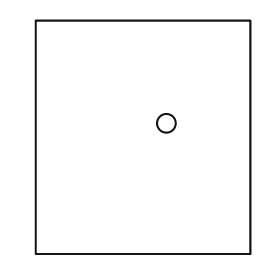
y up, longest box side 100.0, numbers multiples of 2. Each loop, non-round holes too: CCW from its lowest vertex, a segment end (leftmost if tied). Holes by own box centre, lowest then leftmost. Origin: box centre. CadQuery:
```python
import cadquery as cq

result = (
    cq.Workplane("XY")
    .moveTo(-46.0, -50.0)
    .lineTo(46.0, -50.0)
    .lineTo(46.0, 50.0)
    .lineTo(-46.0, 50.0)
    .close()
    .moveTo(10.0, 6.0)
    .circle(4.0)
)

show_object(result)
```